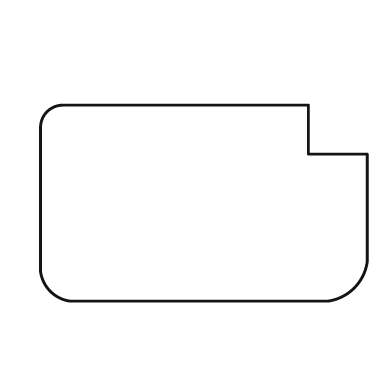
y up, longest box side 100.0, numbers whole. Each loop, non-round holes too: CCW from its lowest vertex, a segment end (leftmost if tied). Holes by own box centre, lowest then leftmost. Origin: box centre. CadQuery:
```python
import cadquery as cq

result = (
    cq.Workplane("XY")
    .moveTo(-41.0, -30.0)
    .lineTo(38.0, -30.0)
    .threePointArc((46.0, -26.0), (50.0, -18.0))
    .lineTo(50.0, 15.0)
    .lineTo(32.0, 15.0)
    .lineTo(32.0, 30.0)
    .lineTo(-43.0, 30.0)
    .threePointArc((-48.0, 28.0), (-50.0, 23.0))
    .lineTo(-50.0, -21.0)
    .threePointArc((-47.0, -27.0), (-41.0, -30.0))
    .close()
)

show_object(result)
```